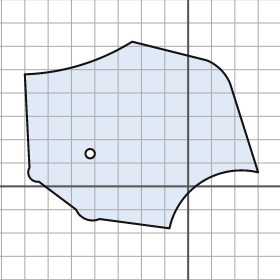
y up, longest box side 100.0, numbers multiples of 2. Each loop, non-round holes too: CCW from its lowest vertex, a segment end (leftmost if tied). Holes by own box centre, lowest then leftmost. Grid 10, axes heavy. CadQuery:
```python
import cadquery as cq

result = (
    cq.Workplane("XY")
    .moveTo(-8.0, -18.0)
    .threePointArc((6.0, 2.0), (30.0, 6.0))
    .lineTo(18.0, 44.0)
    .threePointArc((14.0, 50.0), (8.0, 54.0))
    .lineTo(-24.0, 62.0)
    .threePointArc((-46.0, 52.0), (-70.0, 48.0))
    .lineTo(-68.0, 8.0)
    .threePointArc((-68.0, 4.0), (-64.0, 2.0))
    .lineTo(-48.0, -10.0)
    .threePointArc((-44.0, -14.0), (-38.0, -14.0))
    .close()
    .moveTo(-42.0, 14.0)
    .circle(2.0)
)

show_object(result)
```